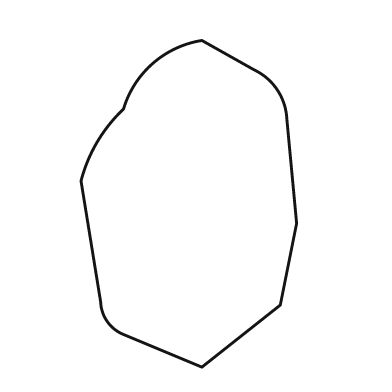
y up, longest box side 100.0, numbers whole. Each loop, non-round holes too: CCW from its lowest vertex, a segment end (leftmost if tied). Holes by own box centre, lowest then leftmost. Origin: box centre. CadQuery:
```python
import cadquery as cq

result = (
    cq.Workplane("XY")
    .moveTo(4.0, -50.0)
    .lineTo(28.0, -31.0)
    .lineTo(33.0, -6.0)
    .lineTo(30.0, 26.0)
    .threePointArc((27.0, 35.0), (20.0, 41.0))
    .lineTo(4.0, 50.0)
    .threePointArc((-11.0, 43.0), (-20.0, 29.0))
    .threePointArc((-28.0, 19.0), (-33.0, 7.0))
    .lineTo(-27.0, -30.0)
    .threePointArc((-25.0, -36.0), (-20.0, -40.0))
    .close()
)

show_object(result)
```